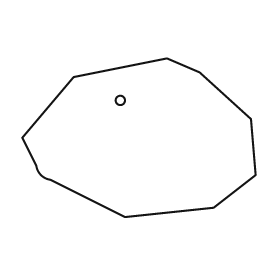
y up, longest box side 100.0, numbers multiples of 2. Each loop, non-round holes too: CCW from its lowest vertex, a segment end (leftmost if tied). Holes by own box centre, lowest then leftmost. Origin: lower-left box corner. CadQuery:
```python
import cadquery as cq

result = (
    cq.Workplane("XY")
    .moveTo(44.0, 0.0)
    .lineTo(82.0, 4.0)
    .lineTo(100.0, 18.0)
    .lineTo(98.0, 42.0)
    .lineTo(76.0, 62.0)
    .lineTo(62.0, 68.0)
    .lineTo(22.0, 60.0)
    .lineTo(0.0, 34.0)
    .lineTo(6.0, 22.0)
    .threePointArc((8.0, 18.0), (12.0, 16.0))
    .close()
    .moveTo(42.0, 50.0)
    .circle(2.0)
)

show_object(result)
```